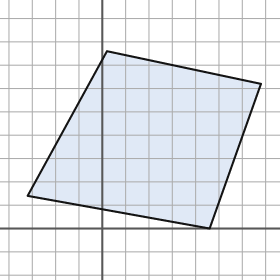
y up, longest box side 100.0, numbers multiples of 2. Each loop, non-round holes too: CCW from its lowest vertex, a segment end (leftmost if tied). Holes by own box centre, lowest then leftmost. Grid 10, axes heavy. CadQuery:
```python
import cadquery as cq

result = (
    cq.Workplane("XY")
    .moveTo(46.0, 0.0)
    .lineTo(68.0, 62.0)
    .lineTo(2.0, 76.0)
    .lineTo(-32.0, 14.0)
    .close()
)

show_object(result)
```